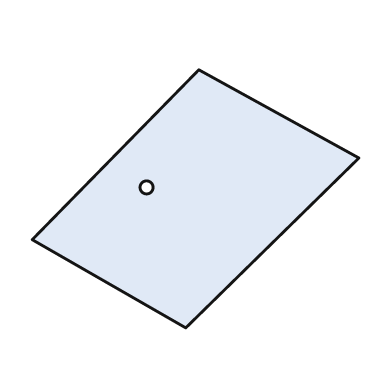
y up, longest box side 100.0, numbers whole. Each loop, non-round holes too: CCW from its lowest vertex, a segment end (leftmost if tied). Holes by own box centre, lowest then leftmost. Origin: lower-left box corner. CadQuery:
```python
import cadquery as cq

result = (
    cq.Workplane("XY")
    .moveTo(47.0, 0.0)
    .lineTo(100.0, 52.0)
    .lineTo(51.0, 79.0)
    .lineTo(0.0, 27.0)
    .close()
    .moveTo(35.0, 43.0)
    .circle(2.0)
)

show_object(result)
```